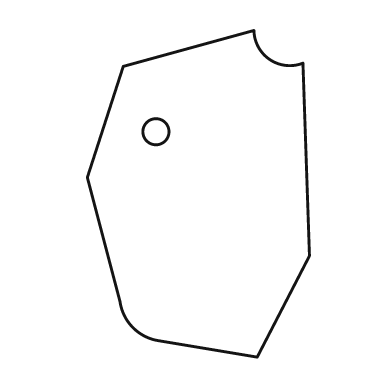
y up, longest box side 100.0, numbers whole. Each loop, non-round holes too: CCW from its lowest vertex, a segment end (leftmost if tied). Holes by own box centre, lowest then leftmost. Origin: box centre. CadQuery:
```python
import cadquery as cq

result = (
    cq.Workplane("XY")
    .moveTo(18.0, -50.0)
    .lineTo(34.0, -19.0)
    .lineTo(32.0, 40.0)
    .threePointArc((22.0, 41.0), (17.0, 50.0))
    .lineTo(-23.0, 39.0)
    .lineTo(-34.0, 5.0)
    .lineTo(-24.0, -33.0)
    .threePointArc((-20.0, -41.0), (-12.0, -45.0))
    .close()
    .moveTo(-13.0, 19.0)
    .circle(4.0)
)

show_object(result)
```